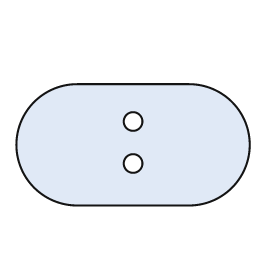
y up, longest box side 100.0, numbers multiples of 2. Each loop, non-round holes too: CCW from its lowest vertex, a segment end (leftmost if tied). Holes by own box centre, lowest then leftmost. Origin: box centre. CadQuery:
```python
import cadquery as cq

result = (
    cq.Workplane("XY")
    .moveTo(-24.0, -26.0)
    .lineTo(24.0, -26.0)
    .threePointArc((50.0, 0.0), (24.0, 26.0))
    .lineTo(-24.0, 26.0)
    .threePointArc((-50.0, 0.0), (-24.0, -26.0))
    .close()
    .moveTo(0.0, -8.0)
    .circle(4.0)
    .moveTo(0.0, 10.0)
    .circle(4.0)
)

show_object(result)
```